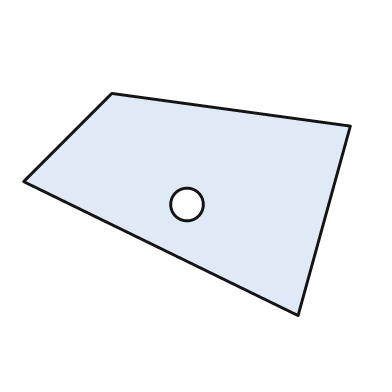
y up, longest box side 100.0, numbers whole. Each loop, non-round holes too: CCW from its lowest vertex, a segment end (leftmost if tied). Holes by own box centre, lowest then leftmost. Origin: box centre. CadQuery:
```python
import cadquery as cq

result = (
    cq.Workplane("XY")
    .moveTo(34.0, -34.0)
    .lineTo(50.0, 24.0)
    .lineTo(-23.0, 34.0)
    .lineTo(-50.0, 7.0)
    .close()
    .moveTo(0.0, 0.0)
    .circle(5.0)
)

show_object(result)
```